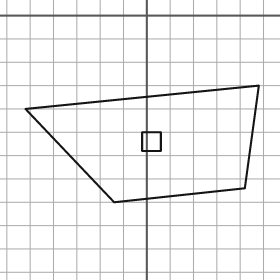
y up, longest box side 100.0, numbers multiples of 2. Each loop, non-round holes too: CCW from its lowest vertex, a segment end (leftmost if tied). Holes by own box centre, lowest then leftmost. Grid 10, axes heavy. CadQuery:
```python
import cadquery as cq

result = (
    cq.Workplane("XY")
    .moveTo(-14.0, -80.0)
    .lineTo(42.0, -74.0)
    .lineTo(48.0, -30.0)
    .lineTo(-52.0, -40.0)
    .close()
    .moveTo(-2.0, -58.0)
    .lineTo(6.0, -58.0)
    .lineTo(6.0, -50.0)
    .lineTo(-2.0, -50.0)
    .close()
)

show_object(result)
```